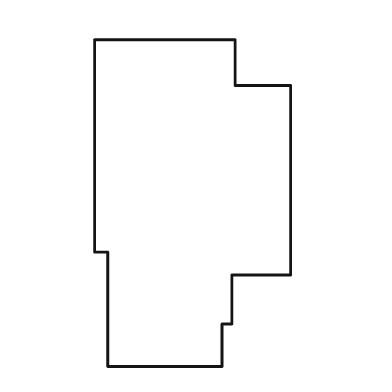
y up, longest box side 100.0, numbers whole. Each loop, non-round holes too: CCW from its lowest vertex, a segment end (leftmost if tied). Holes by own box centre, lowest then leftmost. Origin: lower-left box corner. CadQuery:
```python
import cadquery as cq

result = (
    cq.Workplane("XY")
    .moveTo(4.0, 0.0)
    .lineTo(39.0, 0.0)
    .lineTo(39.0, 13.0)
    .lineTo(42.0, 13.0)
    .lineTo(42.0, 28.0)
    .lineTo(60.0, 28.0)
    .lineTo(60.0, 86.0)
    .lineTo(43.0, 86.0)
    .lineTo(43.0, 100.0)
    .lineTo(0.0, 100.0)
    .lineTo(0.0, 35.0)
    .lineTo(4.0, 35.0)
    .close()
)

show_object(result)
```